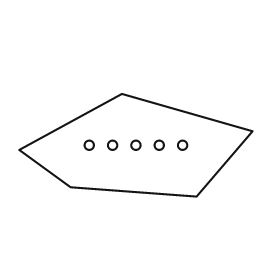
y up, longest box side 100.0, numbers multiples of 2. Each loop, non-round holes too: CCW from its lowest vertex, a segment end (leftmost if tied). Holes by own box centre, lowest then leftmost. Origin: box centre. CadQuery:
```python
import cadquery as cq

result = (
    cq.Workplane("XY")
    .moveTo(26.0, -22.0)
    .lineTo(50.0, 6.0)
    .lineTo(-6.0, 22.0)
    .lineTo(-50.0, -2.0)
    .lineTo(-28.0, -18.0)
    .close()
    .moveTo(-20.0, 0.0)
    .circle(2.0)
    .moveTo(-10.0, 0.0)
    .circle(2.0)
    .moveTo(0.0, 0.0)
    .circle(2.0)
    .moveTo(10.0, 0.0)
    .circle(2.0)
    .moveTo(20.0, 0.0)
    .circle(2.0)
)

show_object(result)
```